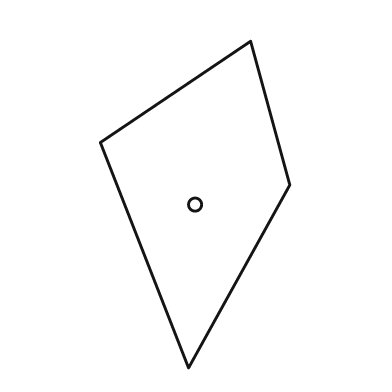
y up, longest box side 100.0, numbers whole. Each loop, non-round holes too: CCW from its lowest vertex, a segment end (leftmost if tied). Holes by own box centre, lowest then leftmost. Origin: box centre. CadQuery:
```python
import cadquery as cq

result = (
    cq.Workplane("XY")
    .moveTo(-2.0, -50.0)
    .lineTo(29.0, 6.0)
    .lineTo(17.0, 50.0)
    .lineTo(-29.0, 19.0)
    .close()
    .moveTo(0.0, 0.0)
    .circle(2.0)
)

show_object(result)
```